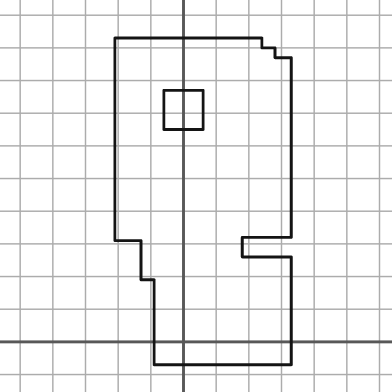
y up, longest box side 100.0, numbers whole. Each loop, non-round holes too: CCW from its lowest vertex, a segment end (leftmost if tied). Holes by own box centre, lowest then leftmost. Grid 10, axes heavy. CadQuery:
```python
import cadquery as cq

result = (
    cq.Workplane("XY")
    .moveTo(-9.0, -7.0)
    .lineTo(33.0, -7.0)
    .lineTo(33.0, 26.0)
    .lineTo(18.0, 26.0)
    .lineTo(18.0, 32.0)
    .lineTo(33.0, 32.0)
    .lineTo(33.0, 87.0)
    .lineTo(28.0, 87.0)
    .lineTo(28.0, 90.0)
    .lineTo(24.0, 90.0)
    .lineTo(24.0, 93.0)
    .lineTo(-21.0, 93.0)
    .lineTo(-21.0, 31.0)
    .lineTo(-13.0, 31.0)
    .lineTo(-13.0, 19.0)
    .lineTo(-9.0, 19.0)
    .close()
    .moveTo(-6.0, 65.0)
    .lineTo(6.0, 65.0)
    .lineTo(6.0, 77.0)
    .lineTo(-6.0, 77.0)
    .close()
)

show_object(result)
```